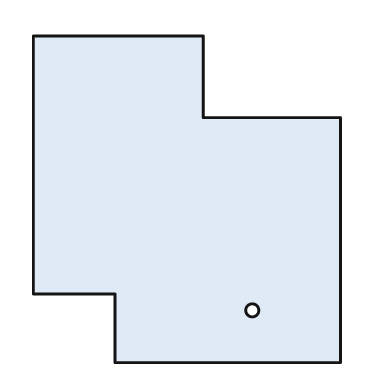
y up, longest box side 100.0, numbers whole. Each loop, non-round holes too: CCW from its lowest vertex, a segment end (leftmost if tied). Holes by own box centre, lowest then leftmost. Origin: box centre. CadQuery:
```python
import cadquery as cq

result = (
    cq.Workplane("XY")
    .moveTo(-22.0, -50.0)
    .lineTo(47.0, -50.0)
    .lineTo(47.0, 25.0)
    .lineTo(5.0, 25.0)
    .lineTo(5.0, 50.0)
    .lineTo(-47.0, 50.0)
    .lineTo(-47.0, -29.0)
    .lineTo(-22.0, -29.0)
    .close()
    .moveTo(20.0, -34.0)
    .circle(2.0)
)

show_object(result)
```